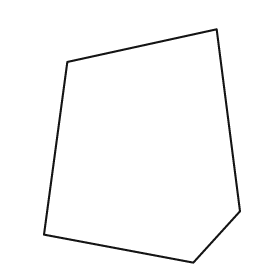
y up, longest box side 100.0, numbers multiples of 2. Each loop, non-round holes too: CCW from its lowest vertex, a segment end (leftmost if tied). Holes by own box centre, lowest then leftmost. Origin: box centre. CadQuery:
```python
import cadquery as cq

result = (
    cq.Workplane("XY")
    .moveTo(22.0, -50.0)
    .lineTo(42.0, -28.0)
    .lineTo(32.0, 50.0)
    .lineTo(-32.0, 36.0)
    .lineTo(-42.0, -38.0)
    .close()
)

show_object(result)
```